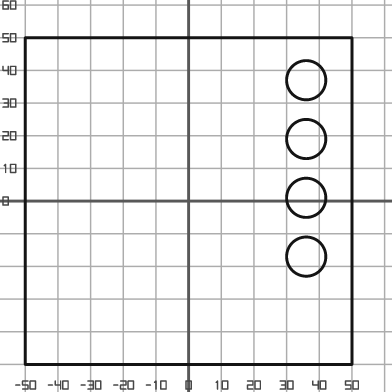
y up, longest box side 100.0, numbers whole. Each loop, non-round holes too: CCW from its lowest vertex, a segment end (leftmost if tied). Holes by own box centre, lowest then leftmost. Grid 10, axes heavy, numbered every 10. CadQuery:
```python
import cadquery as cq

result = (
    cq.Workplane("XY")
    .moveTo(-50.0, -50.0)
    .lineTo(50.0, -50.0)
    .lineTo(50.0, 50.0)
    .lineTo(-50.0, 50.0)
    .close()
    .moveTo(36.0, -17.0)
    .circle(6.0)
    .moveTo(36.0, 1.0)
    .circle(6.0)
    .moveTo(36.0, 19.0)
    .circle(6.0)
    .moveTo(36.0, 37.0)
    .circle(6.0)
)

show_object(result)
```